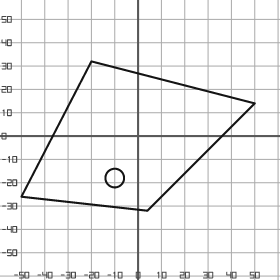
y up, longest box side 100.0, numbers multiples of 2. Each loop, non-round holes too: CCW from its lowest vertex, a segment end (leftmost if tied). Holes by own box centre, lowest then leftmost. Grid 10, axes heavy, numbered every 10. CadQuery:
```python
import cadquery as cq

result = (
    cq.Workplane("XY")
    .moveTo(4.0, -32.0)
    .lineTo(50.0, 14.0)
    .lineTo(-20.0, 32.0)
    .lineTo(-50.0, -26.0)
    .close()
    .moveTo(-10.0, -18.0)
    .circle(4.0)
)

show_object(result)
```